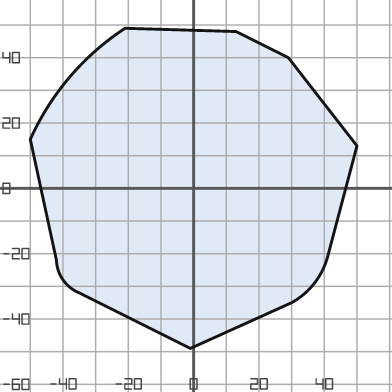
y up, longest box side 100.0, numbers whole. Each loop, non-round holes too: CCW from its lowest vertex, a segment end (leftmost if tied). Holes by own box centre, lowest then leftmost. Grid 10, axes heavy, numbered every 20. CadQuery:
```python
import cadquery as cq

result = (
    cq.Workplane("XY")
    .moveTo(-1.0, -49.0)
    .lineTo(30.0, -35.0)
    .threePointArc((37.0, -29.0), (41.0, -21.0))
    .lineTo(50.0, 13.0)
    .lineTo(29.0, 40.0)
    .lineTo(13.0, 48.0)
    .lineTo(-21.0, 49.0)
    .threePointArc((-38.0, 34.0), (-50.0, 15.0))
    .lineTo(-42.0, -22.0)
    .threePointArc((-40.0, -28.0), (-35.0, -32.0))
    .close()
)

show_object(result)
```